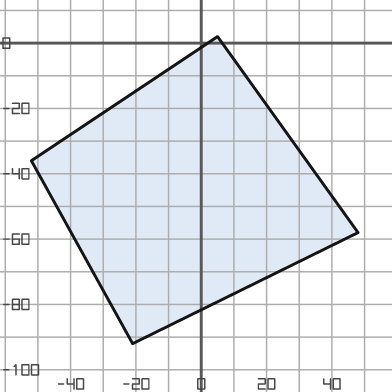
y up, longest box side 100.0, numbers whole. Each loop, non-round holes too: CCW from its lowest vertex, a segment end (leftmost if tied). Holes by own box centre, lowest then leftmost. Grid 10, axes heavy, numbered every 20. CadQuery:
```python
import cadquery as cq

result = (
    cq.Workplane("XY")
    .moveTo(-21.0, -92.0)
    .lineTo(48.0, -58.0)
    .lineTo(5.0, 2.0)
    .lineTo(-52.0, -36.0)
    .close()
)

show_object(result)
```